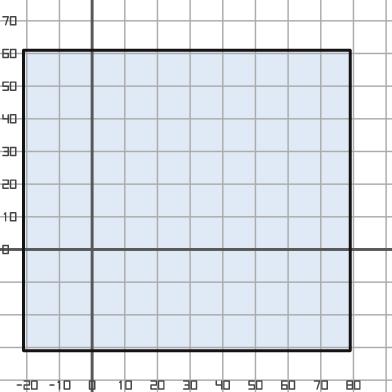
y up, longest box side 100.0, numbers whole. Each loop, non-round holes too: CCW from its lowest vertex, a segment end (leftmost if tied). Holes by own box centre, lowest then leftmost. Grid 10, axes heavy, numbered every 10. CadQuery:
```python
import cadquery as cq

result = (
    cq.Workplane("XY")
    .moveTo(-21.0, -31.0)
    .lineTo(79.0, -31.0)
    .lineTo(79.0, 61.0)
    .lineTo(-21.0, 61.0)
    .close()
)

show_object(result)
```